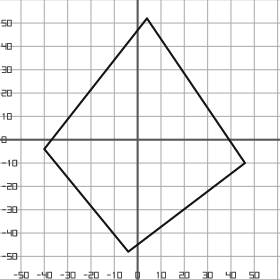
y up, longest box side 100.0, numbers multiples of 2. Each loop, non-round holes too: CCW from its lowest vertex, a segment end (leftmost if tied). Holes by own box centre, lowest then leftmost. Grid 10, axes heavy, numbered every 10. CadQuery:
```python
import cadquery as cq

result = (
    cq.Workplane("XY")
    .moveTo(-4.0, -48.0)
    .lineTo(46.0, -10.0)
    .lineTo(4.0, 52.0)
    .lineTo(-40.0, -4.0)
    .close()
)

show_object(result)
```